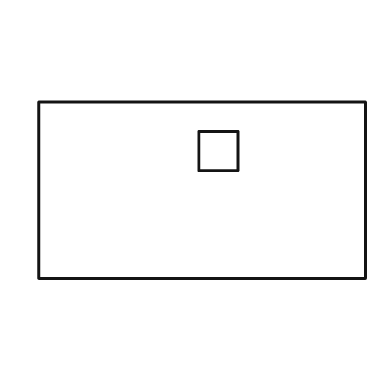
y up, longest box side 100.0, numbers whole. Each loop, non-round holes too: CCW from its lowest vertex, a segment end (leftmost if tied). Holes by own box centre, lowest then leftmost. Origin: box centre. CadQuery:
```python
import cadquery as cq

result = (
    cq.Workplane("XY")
    .moveTo(-50.0, -27.0)
    .lineTo(50.0, -27.0)
    .lineTo(50.0, 27.0)
    .lineTo(-50.0, 27.0)
    .close()
    .moveTo(-1.0, 6.0)
    .lineTo(11.0, 6.0)
    .lineTo(11.0, 18.0)
    .lineTo(-1.0, 18.0)
    .close()
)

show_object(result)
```